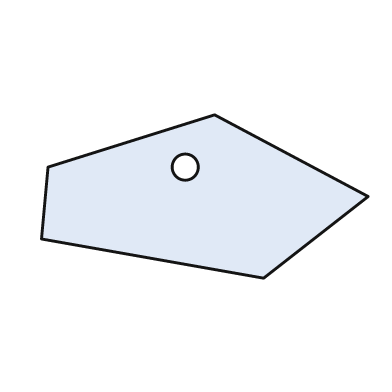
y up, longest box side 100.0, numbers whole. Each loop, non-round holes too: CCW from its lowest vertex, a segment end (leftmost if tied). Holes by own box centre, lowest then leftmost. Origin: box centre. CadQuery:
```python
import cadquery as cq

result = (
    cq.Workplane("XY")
    .moveTo(18.0, -25.0)
    .lineTo(50.0, 0.0)
    .lineTo(3.0, 25.0)
    .lineTo(-48.0, 9.0)
    .lineTo(-50.0, -13.0)
    .close()
    .moveTo(-6.0, 9.0)
    .circle(4.0)
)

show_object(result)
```